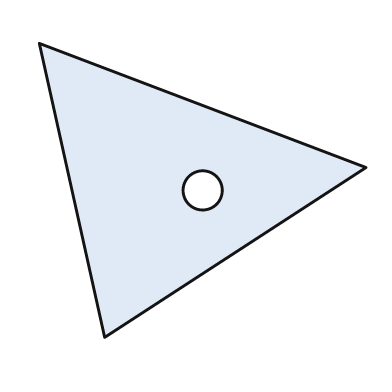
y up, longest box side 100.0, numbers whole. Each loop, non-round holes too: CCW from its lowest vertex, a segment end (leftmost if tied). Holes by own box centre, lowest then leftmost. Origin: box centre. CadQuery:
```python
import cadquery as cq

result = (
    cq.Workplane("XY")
    .moveTo(-30.0, -45.0)
    .lineTo(50.0, 7.0)
    .lineTo(-50.0, 45.0)
    .close()
    .moveTo(0.0, 0.0)
    .circle(6.0)
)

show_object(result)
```